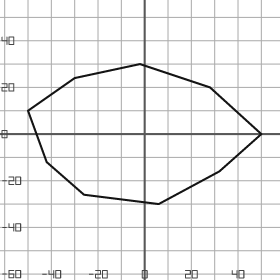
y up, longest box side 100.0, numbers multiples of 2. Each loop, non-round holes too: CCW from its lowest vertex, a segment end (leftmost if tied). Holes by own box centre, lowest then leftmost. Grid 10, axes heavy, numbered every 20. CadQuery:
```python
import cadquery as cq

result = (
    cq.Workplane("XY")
    .moveTo(6.0, -30.0)
    .lineTo(32.0, -16.0)
    .lineTo(50.0, 0.0)
    .lineTo(28.0, 20.0)
    .lineTo(-2.0, 30.0)
    .lineTo(-30.0, 24.0)
    .lineTo(-50.0, 10.0)
    .lineTo(-42.0, -12.0)
    .lineTo(-26.0, -26.0)
    .close()
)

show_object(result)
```